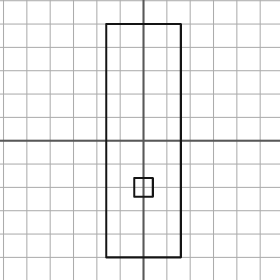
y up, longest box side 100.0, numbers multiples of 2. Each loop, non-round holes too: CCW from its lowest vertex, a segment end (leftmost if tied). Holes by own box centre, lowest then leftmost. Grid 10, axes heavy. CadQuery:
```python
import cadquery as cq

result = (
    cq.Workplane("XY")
    .moveTo(-16.0, -50.0)
    .lineTo(16.0, -50.0)
    .lineTo(16.0, 50.0)
    .lineTo(-16.0, 50.0)
    .close()
    .moveTo(-4.0, -24.0)
    .lineTo(4.0, -24.0)
    .lineTo(4.0, -16.0)
    .lineTo(-4.0, -16.0)
    .close()
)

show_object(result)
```